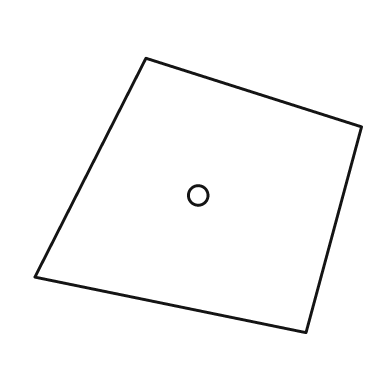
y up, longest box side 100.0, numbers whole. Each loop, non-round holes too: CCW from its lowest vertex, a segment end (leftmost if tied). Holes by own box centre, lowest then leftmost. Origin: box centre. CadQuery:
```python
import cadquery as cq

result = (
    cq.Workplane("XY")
    .moveTo(33.0, -42.0)
    .lineTo(50.0, 21.0)
    .lineTo(-16.0, 42.0)
    .lineTo(-50.0, -25.0)
    .close()
    .moveTo(0.0, 0.0)
    .circle(3.0)
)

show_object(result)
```